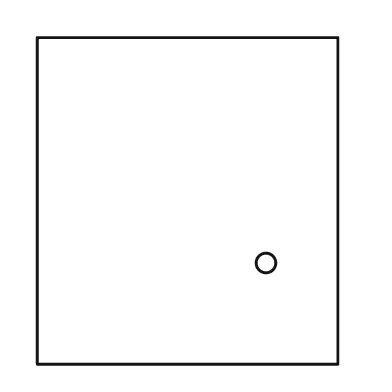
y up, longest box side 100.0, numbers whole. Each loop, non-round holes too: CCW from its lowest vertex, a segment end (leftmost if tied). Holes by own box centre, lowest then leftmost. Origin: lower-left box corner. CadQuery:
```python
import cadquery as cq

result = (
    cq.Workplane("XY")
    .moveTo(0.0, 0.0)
    .lineTo(92.0, 0.0)
    .lineTo(92.0, 100.0)
    .lineTo(0.0, 100.0)
    .close()
    .moveTo(70.0, 31.0)
    .circle(3.0)
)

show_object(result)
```